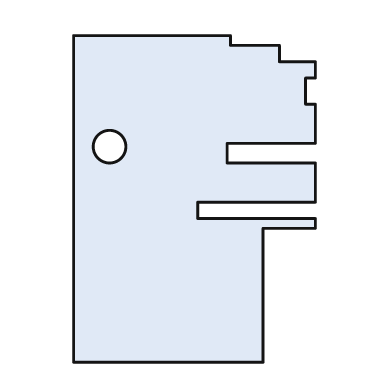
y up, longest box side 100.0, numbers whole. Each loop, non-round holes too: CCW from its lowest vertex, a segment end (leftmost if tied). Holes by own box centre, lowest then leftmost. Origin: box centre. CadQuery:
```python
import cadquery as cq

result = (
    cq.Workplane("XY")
    .moveTo(-37.0, -50.0)
    .lineTo(21.0, -50.0)
    .lineTo(21.0, -9.0)
    .lineTo(37.0, -9.0)
    .lineTo(37.0, -6.0)
    .lineTo(1.0, -6.0)
    .lineTo(1.0, -1.0)
    .lineTo(37.0, -1.0)
    .lineTo(37.0, 11.0)
    .lineTo(10.0, 11.0)
    .lineTo(10.0, 17.0)
    .lineTo(37.0, 17.0)
    .lineTo(37.0, 29.0)
    .lineTo(34.0, 29.0)
    .lineTo(34.0, 37.0)
    .lineTo(37.0, 37.0)
    .lineTo(37.0, 42.0)
    .lineTo(26.0, 42.0)
    .lineTo(26.0, 47.0)
    .lineTo(11.0, 47.0)
    .lineTo(11.0, 50.0)
    .lineTo(-37.0, 50.0)
    .close()
    .moveTo(-26.0, 16.0)
    .circle(5.0)
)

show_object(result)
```